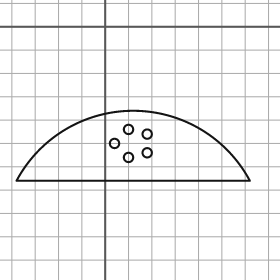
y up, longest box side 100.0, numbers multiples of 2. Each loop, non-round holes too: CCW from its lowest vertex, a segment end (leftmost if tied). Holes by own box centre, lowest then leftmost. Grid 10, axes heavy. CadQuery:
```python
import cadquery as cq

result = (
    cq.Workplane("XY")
    .moveTo(-38.0, -66.0)
    .lineTo(62.0, -66.0)
    .threePointArc((12.0, -36.0), (-38.0, -66.0))
    .close()
    .moveTo(10.0, -56.0)
    .circle(2.0)
    .moveTo(18.0, -54.0)
    .circle(2.0)
    .moveTo(4.0, -50.0)
    .circle(2.0)
    .moveTo(18.0, -46.0)
    .circle(2.0)
    .moveTo(10.0, -44.0)
    .circle(2.0)
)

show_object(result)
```